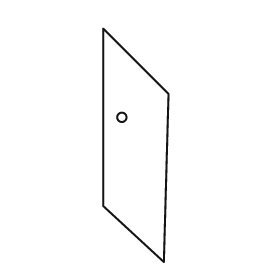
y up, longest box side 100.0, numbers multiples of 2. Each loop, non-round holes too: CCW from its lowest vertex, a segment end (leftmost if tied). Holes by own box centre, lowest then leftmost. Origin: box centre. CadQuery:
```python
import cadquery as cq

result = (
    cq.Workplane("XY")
    .moveTo(12.0, -50.0)
    .lineTo(14.0, 22.0)
    .lineTo(-14.0, 50.0)
    .lineTo(-14.0, -26.0)
    .close()
    .moveTo(-6.0, 12.0)
    .circle(2.0)
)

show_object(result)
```